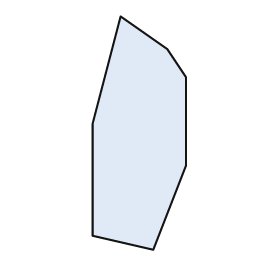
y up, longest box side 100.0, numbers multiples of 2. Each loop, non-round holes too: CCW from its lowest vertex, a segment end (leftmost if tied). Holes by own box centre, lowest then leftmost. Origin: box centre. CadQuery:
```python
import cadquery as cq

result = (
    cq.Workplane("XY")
    .moveTo(6.0, -50.0)
    .lineTo(20.0, -14.0)
    .lineTo(20.0, 24.0)
    .lineTo(12.0, 36.0)
    .lineTo(-8.0, 50.0)
    .lineTo(-20.0, 4.0)
    .lineTo(-20.0, -44.0)
    .close()
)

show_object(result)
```